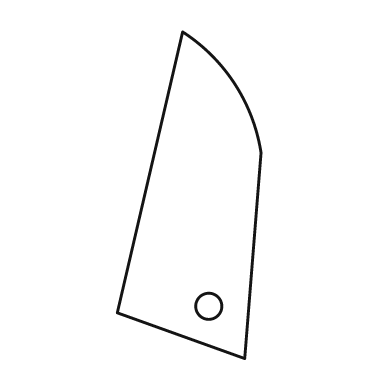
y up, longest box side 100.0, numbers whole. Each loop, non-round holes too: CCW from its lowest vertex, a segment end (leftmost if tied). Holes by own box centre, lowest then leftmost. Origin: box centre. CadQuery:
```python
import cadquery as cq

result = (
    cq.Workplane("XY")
    .moveTo(17.0, -50.0)
    .lineTo(22.0, 13.0)
    .threePointArc((14.0, 34.0), (-2.0, 50.0))
    .lineTo(-22.0, -36.0)
    .close()
    .moveTo(6.0, -34.0)
    .circle(4.0)
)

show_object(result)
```